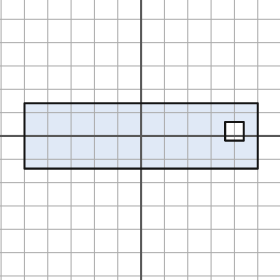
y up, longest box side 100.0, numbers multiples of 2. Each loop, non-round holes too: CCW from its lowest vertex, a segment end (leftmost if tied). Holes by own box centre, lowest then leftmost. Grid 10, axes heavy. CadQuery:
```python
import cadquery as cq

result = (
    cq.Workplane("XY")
    .moveTo(-50.0, -14.0)
    .lineTo(50.0, -14.0)
    .lineTo(50.0, 14.0)
    .lineTo(-50.0, 14.0)
    .close()
    .moveTo(36.0, -2.0)
    .lineTo(44.0, -2.0)
    .lineTo(44.0, 6.0)
    .lineTo(36.0, 6.0)
    .close()
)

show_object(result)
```